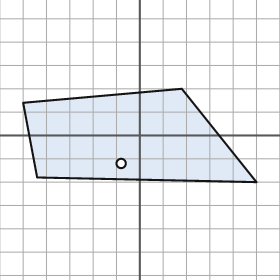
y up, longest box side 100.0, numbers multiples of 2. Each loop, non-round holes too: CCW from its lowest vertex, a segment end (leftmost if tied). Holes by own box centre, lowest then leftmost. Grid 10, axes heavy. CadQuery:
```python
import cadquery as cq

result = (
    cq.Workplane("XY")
    .moveTo(50.0, -20.0)
    .lineTo(18.0, 20.0)
    .lineTo(-50.0, 14.0)
    .lineTo(-44.0, -18.0)
    .close()
    .moveTo(-8.0, -12.0)
    .circle(2.0)
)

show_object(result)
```